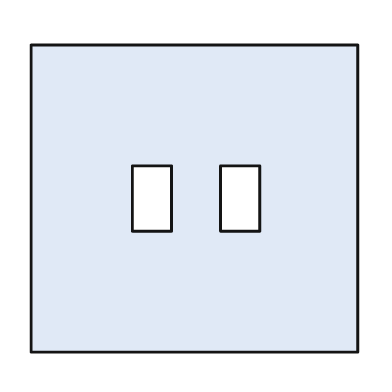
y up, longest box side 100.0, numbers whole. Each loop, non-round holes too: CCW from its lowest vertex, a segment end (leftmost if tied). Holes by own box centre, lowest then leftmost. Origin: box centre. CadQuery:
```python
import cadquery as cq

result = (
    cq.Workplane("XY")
    .moveTo(-50.0, -47.0)
    .lineTo(50.0, -47.0)
    .lineTo(50.0, 47.0)
    .lineTo(-50.0, 47.0)
    .close()
    .moveTo(-19.0, -10.0)
    .lineTo(-7.0, -10.0)
    .lineTo(-7.0, 10.0)
    .lineTo(-19.0, 10.0)
    .close()
    .moveTo(8.0, -10.0)
    .lineTo(20.0, -10.0)
    .lineTo(20.0, 10.0)
    .lineTo(8.0, 10.0)
    .close()
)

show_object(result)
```